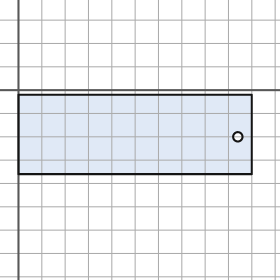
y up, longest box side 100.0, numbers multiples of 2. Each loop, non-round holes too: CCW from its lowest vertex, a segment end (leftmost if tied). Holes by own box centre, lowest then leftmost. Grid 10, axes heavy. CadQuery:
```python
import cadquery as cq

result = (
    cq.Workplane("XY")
    .moveTo(0.0, -36.0)
    .lineTo(100.0, -36.0)
    .lineTo(100.0, -2.0)
    .lineTo(0.0, -2.0)
    .close()
    .moveTo(94.0, -20.0)
    .circle(2.0)
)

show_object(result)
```